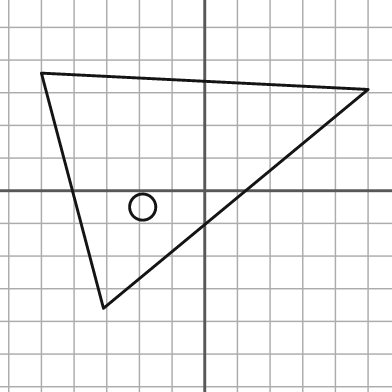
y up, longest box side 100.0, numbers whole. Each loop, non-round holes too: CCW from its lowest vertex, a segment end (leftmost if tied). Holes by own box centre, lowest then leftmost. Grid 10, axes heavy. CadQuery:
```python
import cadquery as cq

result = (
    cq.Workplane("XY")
    .moveTo(-31.0, -36.0)
    .lineTo(50.0, 31.0)
    .lineTo(-50.0, 36.0)
    .close()
    .moveTo(-19.0, -5.0)
    .circle(4.0)
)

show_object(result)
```